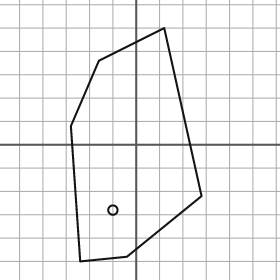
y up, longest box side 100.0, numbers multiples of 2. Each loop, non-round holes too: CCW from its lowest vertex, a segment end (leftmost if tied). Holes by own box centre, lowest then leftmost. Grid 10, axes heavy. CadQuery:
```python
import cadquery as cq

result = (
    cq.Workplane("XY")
    .moveTo(-24.0, -50.0)
    .lineTo(-4.0, -48.0)
    .lineTo(28.0, -22.0)
    .lineTo(12.0, 50.0)
    .lineTo(-16.0, 36.0)
    .lineTo(-28.0, 8.0)
    .close()
    .moveTo(-10.0, -28.0)
    .circle(2.0)
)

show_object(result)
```